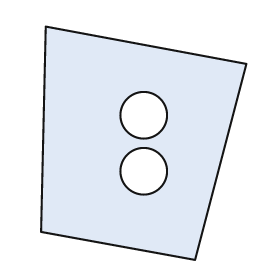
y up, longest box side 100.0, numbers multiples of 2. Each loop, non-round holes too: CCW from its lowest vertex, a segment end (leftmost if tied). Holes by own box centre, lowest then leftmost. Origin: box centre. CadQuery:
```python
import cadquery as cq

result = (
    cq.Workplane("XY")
    .moveTo(22.0, -50.0)
    .lineTo(44.0, 34.0)
    .lineTo(-42.0, 50.0)
    .lineTo(-44.0, -38.0)
    .close()
    .moveTo(0.0, -12.0)
    .circle(10.0)
    .moveTo(0.0, 12.0)
    .circle(10.0)
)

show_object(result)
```